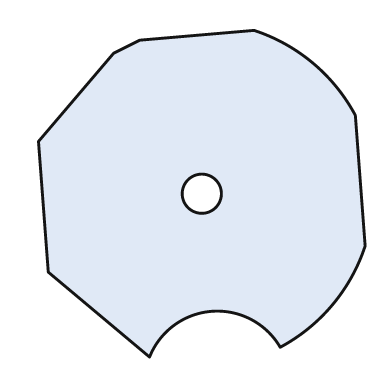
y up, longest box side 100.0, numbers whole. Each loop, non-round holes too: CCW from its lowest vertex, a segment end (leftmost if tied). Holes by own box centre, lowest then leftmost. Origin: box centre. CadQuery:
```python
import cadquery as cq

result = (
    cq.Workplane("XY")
    .moveTo(-16.0, -50.0)
    .threePointArc((3.0, -36.0), (24.0, -47.0))
    .threePointArc((40.0, -34.0), (50.0, -16.0))
    .lineTo(47.0, 24.0)
    .threePointArc((34.0, 40.0), (16.0, 50.0))
    .lineTo(-19.0, 47.0)
    .lineTo(-27.0, 43.0)
    .lineTo(-50.0, 16.0)
    .lineTo(-47.0, -24.0)
    .close()
    .moveTo(0.0, 0.0)
    .circle(6.0)
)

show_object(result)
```